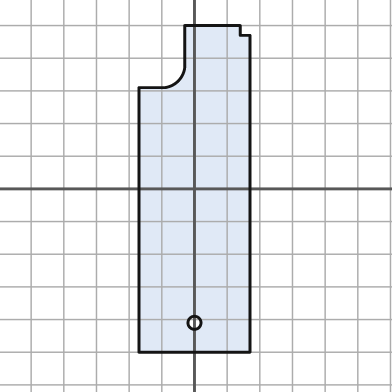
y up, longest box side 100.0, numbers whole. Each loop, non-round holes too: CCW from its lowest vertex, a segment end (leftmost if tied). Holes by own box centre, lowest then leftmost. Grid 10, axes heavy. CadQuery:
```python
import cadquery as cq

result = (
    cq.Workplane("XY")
    .moveTo(-17.0, -50.0)
    .lineTo(17.0, -50.0)
    .lineTo(17.0, 47.0)
    .lineTo(14.0, 47.0)
    .lineTo(14.0, 50.0)
    .lineTo(-3.0, 50.0)
    .lineTo(-3.0, 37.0)
    .threePointArc((-5.0, 33.0), (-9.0, 31.0))
    .lineTo(-17.0, 31.0)
    .close()
    .moveTo(0.0, -41.0)
    .circle(2.0)
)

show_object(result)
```